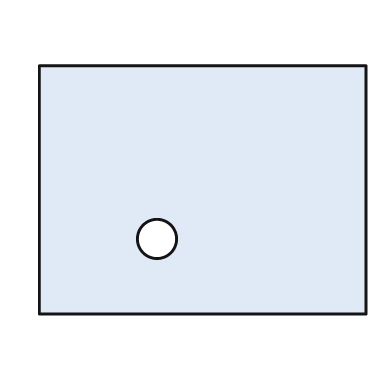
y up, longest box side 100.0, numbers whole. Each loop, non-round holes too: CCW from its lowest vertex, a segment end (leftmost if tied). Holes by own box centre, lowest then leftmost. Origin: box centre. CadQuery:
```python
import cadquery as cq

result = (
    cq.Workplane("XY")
    .moveTo(-50.0, -38.0)
    .lineTo(50.0, -38.0)
    .lineTo(50.0, 38.0)
    .lineTo(-50.0, 38.0)
    .close()
    .moveTo(-14.0, -15.0)
    .circle(6.0)
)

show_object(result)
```